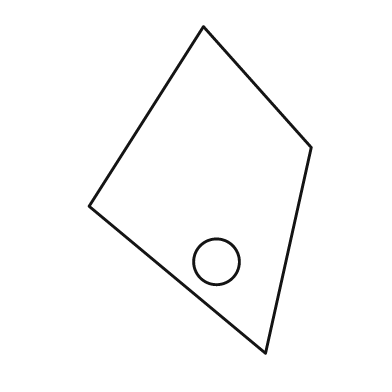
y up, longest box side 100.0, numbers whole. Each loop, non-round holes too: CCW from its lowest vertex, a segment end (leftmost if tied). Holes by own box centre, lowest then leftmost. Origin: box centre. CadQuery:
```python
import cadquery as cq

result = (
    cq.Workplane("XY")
    .moveTo(20.0, -50.0)
    .lineTo(34.0, 13.0)
    .lineTo(1.0, 50.0)
    .lineTo(-34.0, -5.0)
    .close()
    .moveTo(5.0, -22.0)
    .circle(7.0)
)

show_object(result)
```